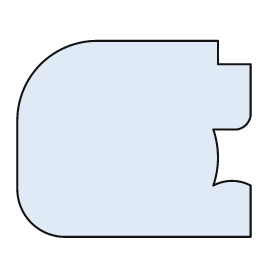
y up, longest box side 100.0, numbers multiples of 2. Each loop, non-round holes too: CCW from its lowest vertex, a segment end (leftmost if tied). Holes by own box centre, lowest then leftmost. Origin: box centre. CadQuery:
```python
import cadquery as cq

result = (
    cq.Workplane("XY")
    .moveTo(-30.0, -42.0)
    .lineTo(50.0, -42.0)
    .lineTo(50.0, -20.0)
    .threePointArc((42.0, -18.0), (34.0, -20.0))
    .threePointArc((36.0, -8.0), (34.0, 4.0))
    .lineTo(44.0, 4.0)
    .threePointArc((48.0, 6.0), (50.0, 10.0))
    .lineTo(50.0, 32.0)
    .lineTo(36.0, 32.0)
    .lineTo(36.0, 42.0)
    .lineTo(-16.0, 42.0)
    .threePointArc((-40.0, 32.0), (-50.0, 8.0))
    .lineTo(-50.0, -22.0)
    .threePointArc((-44.0, -36.0), (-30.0, -42.0))
    .close()
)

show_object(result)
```